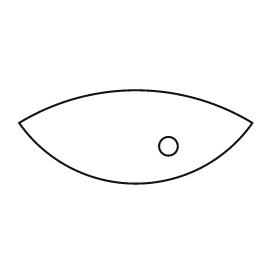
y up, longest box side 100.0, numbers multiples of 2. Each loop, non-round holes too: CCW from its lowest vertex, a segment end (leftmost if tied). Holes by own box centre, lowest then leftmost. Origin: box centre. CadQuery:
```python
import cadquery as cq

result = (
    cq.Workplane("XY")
    .moveTo(-50.0, 6.0)
    .threePointArc((0.0, -20.0), (50.0, 6.0))
    .threePointArc((0.0, 20.0), (-50.0, 6.0))
    .close()
    .moveTo(14.0, -4.0)
    .circle(4.0)
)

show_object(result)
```